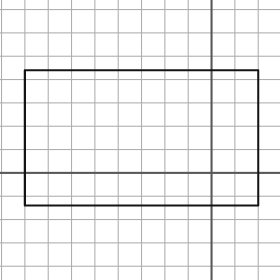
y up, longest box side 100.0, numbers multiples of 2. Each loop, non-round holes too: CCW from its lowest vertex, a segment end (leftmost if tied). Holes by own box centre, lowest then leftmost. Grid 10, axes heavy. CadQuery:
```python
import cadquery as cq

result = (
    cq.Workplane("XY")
    .moveTo(-80.0, -14.0)
    .lineTo(20.0, -14.0)
    .lineTo(20.0, 44.0)
    .lineTo(-80.0, 44.0)
    .close()
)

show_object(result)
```